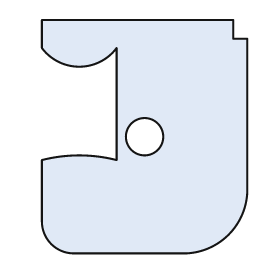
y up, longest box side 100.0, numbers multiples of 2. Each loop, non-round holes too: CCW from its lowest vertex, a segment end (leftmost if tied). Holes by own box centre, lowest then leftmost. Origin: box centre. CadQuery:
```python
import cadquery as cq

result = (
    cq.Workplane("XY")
    .moveTo(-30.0, -50.0)
    .lineTo(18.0, -50.0)
    .threePointArc((36.0, -42.0), (44.0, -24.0))
    .lineTo(44.0, 42.0)
    .lineTo(38.0, 42.0)
    .lineTo(38.0, 50.0)
    .lineTo(-44.0, 50.0)
    .lineTo(-44.0, 38.0)
    .threePointArc((-28.0, 30.0), (-12.0, 38.0))
    .lineTo(-12.0, -10.0)
    .threePointArc((-28.0, -8.0), (-44.0, -10.0))
    .lineTo(-44.0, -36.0)
    .threePointArc((-40.0, -46.0), (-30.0, -50.0))
    .close()
    .moveTo(0.0, 0.0)
    .circle(8.0)
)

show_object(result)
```